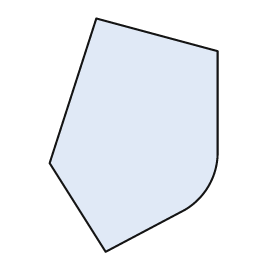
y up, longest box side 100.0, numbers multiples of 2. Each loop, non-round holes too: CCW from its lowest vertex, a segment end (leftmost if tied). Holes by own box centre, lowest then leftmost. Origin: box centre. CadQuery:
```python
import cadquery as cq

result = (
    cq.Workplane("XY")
    .moveTo(-12.0, -50.0)
    .lineTo(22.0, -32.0)
    .threePointArc((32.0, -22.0), (36.0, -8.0))
    .lineTo(36.0, 36.0)
    .lineTo(-16.0, 50.0)
    .lineTo(-36.0, -12.0)
    .close()
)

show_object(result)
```